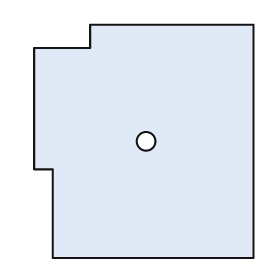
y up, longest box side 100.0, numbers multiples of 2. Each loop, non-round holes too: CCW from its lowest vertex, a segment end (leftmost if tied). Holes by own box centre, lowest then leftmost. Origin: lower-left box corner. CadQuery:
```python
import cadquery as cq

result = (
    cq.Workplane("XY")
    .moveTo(8.0, 0.0)
    .lineTo(94.0, 0.0)
    .lineTo(94.0, 100.0)
    .lineTo(24.0, 100.0)
    .lineTo(24.0, 90.0)
    .lineTo(0.0, 90.0)
    .lineTo(0.0, 38.0)
    .lineTo(8.0, 38.0)
    .close()
    .moveTo(48.0, 50.0)
    .circle(4.0)
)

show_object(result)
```